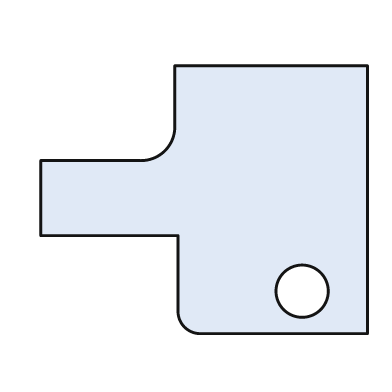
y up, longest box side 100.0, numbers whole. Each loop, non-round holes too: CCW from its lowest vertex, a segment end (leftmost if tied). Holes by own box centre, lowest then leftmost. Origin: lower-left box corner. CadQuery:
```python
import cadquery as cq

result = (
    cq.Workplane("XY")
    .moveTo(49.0, 0.0)
    .lineTo(100.0, 0.0)
    .lineTo(100.0, 82.0)
    .lineTo(41.0, 82.0)
    .lineTo(41.0, 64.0)
    .threePointArc((38.0, 56.0), (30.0, 53.0))
    .lineTo(0.0, 53.0)
    .lineTo(0.0, 30.0)
    .lineTo(42.0, 30.0)
    .lineTo(42.0, 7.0)
    .threePointArc((44.0, 2.0), (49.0, 0.0))
    .close()
    .moveTo(80.0, 13.0)
    .circle(8.0)
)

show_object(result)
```